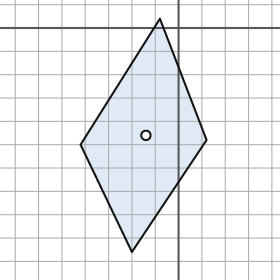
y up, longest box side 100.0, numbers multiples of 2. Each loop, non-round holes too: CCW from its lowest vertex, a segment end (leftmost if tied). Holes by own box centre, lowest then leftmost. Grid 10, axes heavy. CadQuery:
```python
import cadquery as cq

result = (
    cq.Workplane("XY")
    .moveTo(-20.0, -96.0)
    .lineTo(12.0, -48.0)
    .lineTo(-8.0, 4.0)
    .lineTo(-42.0, -50.0)
    .close()
    .moveTo(-14.0, -46.0)
    .circle(2.0)
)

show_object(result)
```